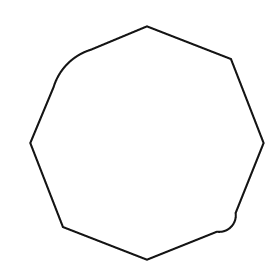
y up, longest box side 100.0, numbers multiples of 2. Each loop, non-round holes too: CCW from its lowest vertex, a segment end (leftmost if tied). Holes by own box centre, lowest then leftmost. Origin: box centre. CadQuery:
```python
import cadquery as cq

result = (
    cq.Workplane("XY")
    .moveTo(0.0, -50.0)
    .lineTo(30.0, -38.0)
    .threePointArc((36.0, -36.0), (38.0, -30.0))
    .lineTo(50.0, 0.0)
    .lineTo(36.0, 36.0)
    .lineTo(0.0, 50.0)
    .lineTo(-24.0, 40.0)
    .threePointArc((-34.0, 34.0), (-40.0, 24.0))
    .lineTo(-50.0, 0.0)
    .lineTo(-36.0, -36.0)
    .close()
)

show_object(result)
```